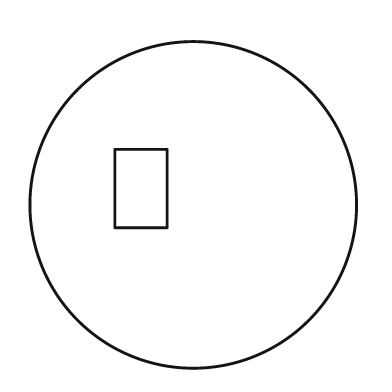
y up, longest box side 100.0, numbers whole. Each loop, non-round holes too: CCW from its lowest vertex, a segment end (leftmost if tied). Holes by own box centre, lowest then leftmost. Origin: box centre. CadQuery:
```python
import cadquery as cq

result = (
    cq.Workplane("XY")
    .moveTo(0.0, 0.0)
    .circle(50.0)
    .moveTo(-24.0, -7.0)
    .lineTo(-8.0, -7.0)
    .lineTo(-8.0, 17.0)
    .lineTo(-24.0, 17.0)
    .close()
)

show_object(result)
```